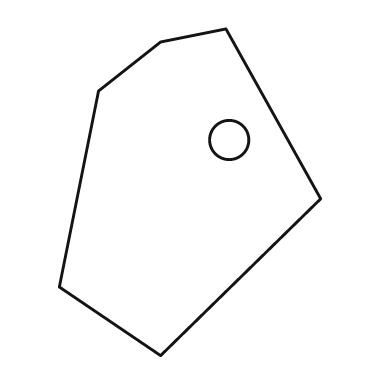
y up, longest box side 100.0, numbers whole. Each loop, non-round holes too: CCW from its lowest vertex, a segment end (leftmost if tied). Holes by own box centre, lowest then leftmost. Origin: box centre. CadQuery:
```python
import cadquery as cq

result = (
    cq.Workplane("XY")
    .moveTo(-9.0, -50.0)
    .lineTo(40.0, -2.0)
    .lineTo(11.0, 50.0)
    .lineTo(-9.0, 46.0)
    .lineTo(-28.0, 31.0)
    .lineTo(-40.0, -29.0)
    .close()
    .moveTo(12.0, 16.0)
    .circle(6.0)
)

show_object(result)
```